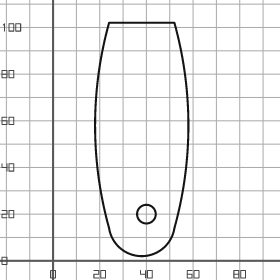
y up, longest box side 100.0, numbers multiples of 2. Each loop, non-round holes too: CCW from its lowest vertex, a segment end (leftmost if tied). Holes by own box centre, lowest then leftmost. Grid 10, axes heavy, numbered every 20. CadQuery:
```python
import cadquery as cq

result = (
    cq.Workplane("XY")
    .moveTo(24.0, 14.0)
    .threePointArc((38.0, 2.0), (52.0, 14.0))
    .threePointArc((58.0, 58.0), (52.0, 102.0))
    .lineTo(24.0, 102.0)
    .threePointArc((18.0, 58.0), (24.0, 14.0))
    .close()
    .moveTo(40.0, 20.0)
    .circle(4.0)
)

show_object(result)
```